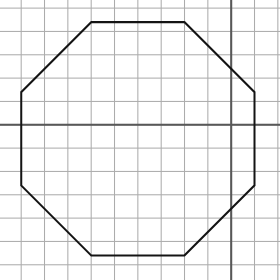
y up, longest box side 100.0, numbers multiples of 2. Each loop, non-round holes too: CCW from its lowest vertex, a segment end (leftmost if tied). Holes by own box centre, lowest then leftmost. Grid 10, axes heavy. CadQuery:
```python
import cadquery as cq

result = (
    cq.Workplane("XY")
    .moveTo(-60.0, -56.0)
    .lineTo(-20.0, -56.0)
    .lineTo(10.0, -26.0)
    .lineTo(10.0, 14.0)
    .lineTo(-20.0, 44.0)
    .lineTo(-60.0, 44.0)
    .lineTo(-90.0, 14.0)
    .lineTo(-90.0, -26.0)
    .close()
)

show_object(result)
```